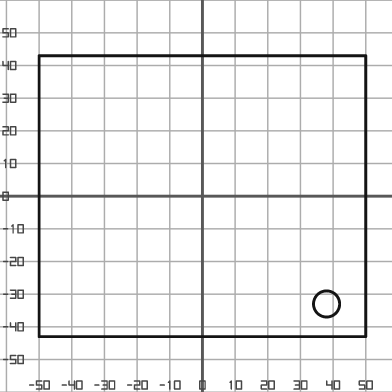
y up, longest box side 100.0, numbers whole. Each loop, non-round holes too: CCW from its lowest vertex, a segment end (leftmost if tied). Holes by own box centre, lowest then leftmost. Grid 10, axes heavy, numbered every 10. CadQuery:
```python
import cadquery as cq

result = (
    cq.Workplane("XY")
    .moveTo(-50.0, -43.0)
    .lineTo(50.0, -43.0)
    .lineTo(50.0, 43.0)
    .lineTo(-50.0, 43.0)
    .close()
    .moveTo(38.0, -33.0)
    .circle(4.0)
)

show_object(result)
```